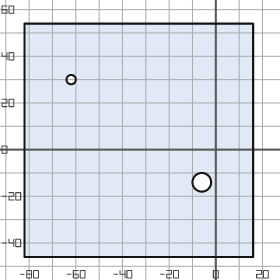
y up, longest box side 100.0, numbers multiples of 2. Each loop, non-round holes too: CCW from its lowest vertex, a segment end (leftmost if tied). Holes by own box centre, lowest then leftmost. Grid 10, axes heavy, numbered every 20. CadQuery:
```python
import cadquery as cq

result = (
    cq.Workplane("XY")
    .moveTo(-82.0, -46.0)
    .lineTo(16.0, -46.0)
    .lineTo(16.0, 54.0)
    .lineTo(-82.0, 54.0)
    .close()
    .moveTo(-6.0, -14.0)
    .circle(4.0)
    .moveTo(-62.0, 30.0)
    .circle(2.0)
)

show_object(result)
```